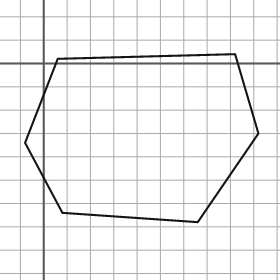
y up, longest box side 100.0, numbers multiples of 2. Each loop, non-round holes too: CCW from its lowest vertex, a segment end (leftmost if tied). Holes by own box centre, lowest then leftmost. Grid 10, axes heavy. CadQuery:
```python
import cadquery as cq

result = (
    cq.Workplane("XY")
    .moveTo(66.0, -68.0)
    .lineTo(92.0, -30.0)
    .lineTo(82.0, 4.0)
    .lineTo(6.0, 2.0)
    .lineTo(-8.0, -34.0)
    .lineTo(8.0, -64.0)
    .close()
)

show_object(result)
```